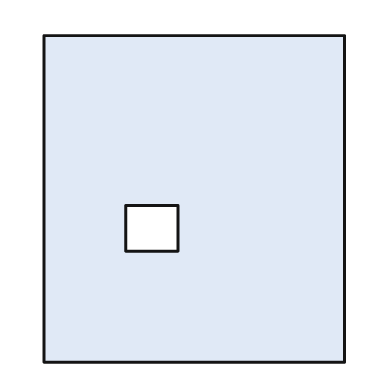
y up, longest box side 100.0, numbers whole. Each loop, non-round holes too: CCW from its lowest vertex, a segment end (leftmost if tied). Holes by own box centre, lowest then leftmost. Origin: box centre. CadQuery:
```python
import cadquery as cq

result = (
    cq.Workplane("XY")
    .moveTo(-46.0, -50.0)
    .lineTo(46.0, -50.0)
    .lineTo(46.0, 50.0)
    .lineTo(-46.0, 50.0)
    .close()
    .moveTo(-21.0, -16.0)
    .lineTo(-5.0, -16.0)
    .lineTo(-5.0, -2.0)
    .lineTo(-21.0, -2.0)
    .close()
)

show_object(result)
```